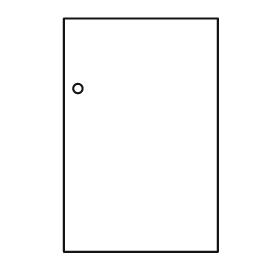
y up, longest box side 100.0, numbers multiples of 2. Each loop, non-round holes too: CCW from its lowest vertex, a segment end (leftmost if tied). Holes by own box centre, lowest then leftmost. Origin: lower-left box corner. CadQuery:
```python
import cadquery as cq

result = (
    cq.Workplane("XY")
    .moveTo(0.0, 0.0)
    .lineTo(66.0, 0.0)
    .lineTo(66.0, 100.0)
    .lineTo(0.0, 100.0)
    .close()
    .moveTo(6.0, 70.0)
    .circle(2.0)
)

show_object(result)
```